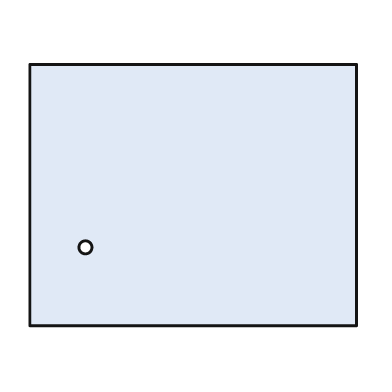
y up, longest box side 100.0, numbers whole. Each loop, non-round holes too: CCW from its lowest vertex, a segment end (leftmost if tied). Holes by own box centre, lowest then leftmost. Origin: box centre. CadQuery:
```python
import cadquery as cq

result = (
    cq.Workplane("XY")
    .moveTo(-50.0, -40.0)
    .lineTo(50.0, -40.0)
    .lineTo(50.0, 40.0)
    .lineTo(-50.0, 40.0)
    .close()
    .moveTo(-33.0, -16.0)
    .circle(2.0)
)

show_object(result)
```